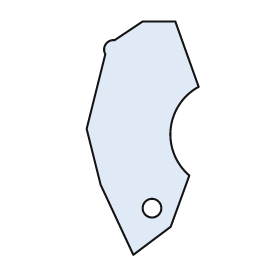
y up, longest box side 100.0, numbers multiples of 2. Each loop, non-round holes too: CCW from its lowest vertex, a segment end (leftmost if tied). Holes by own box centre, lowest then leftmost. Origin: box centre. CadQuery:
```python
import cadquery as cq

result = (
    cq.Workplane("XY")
    .moveTo(-4.0, -50.0)
    .lineTo(12.0, -38.0)
    .lineTo(20.0, -16.0)
    .threePointArc((12.0, 4.0), (24.0, 22.0))
    .lineTo(14.0, 50.0)
    .lineTo(0.0, 50.0)
    .lineTo(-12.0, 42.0)
    .threePointArc((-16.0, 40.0), (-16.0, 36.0))
    .lineTo(-24.0, 4.0)
    .lineTo(-18.0, -20.0)
    .close()
    .moveTo(4.0, -30.0)
    .circle(4.0)
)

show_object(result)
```